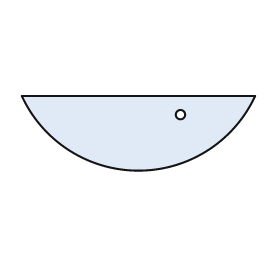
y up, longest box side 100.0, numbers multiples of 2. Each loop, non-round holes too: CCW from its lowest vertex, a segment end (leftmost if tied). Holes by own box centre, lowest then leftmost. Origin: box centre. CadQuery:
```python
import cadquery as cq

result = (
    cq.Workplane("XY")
    .moveTo(-50.0, 16.0)
    .threePointArc((0.0, -16.0), (50.0, 16.0))
    .close()
    .moveTo(18.0, 8.0)
    .circle(2.0)
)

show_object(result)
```